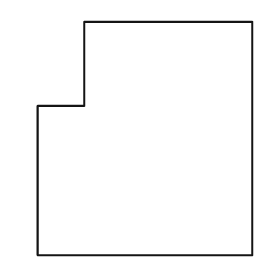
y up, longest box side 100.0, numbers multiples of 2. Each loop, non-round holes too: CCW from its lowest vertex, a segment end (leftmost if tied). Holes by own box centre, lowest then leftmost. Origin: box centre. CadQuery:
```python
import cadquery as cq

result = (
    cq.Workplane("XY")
    .moveTo(-46.0, -50.0)
    .lineTo(46.0, -50.0)
    .lineTo(46.0, 50.0)
    .lineTo(-26.0, 50.0)
    .lineTo(-26.0, 14.0)
    .lineTo(-46.0, 14.0)
    .close()
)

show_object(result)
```